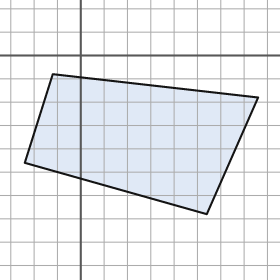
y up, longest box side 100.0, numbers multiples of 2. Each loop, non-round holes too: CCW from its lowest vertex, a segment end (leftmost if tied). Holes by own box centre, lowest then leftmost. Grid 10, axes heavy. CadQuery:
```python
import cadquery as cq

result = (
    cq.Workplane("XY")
    .moveTo(54.0, -68.0)
    .lineTo(76.0, -18.0)
    .lineTo(-12.0, -8.0)
    .lineTo(-24.0, -46.0)
    .close()
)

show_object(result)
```